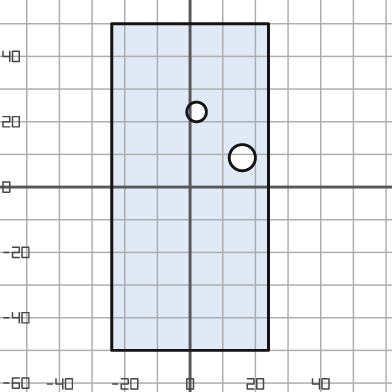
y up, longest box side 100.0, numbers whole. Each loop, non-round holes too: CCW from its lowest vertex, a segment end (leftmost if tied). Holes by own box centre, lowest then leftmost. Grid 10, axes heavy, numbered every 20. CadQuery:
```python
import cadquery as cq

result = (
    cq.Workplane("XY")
    .moveTo(-24.0, -50.0)
    .lineTo(24.0, -50.0)
    .lineTo(24.0, 50.0)
    .lineTo(-24.0, 50.0)
    .close()
    .moveTo(16.0, 9.0)
    .circle(4.0)
    .moveTo(2.0, 23.0)
    .circle(3.0)
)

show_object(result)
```